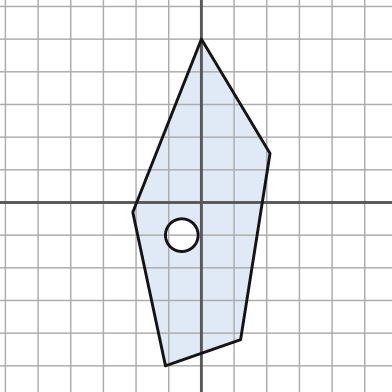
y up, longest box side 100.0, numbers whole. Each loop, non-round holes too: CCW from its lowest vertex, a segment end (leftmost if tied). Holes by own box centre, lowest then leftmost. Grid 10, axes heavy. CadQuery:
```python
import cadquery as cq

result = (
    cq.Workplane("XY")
    .moveTo(-11.0, -50.0)
    .lineTo(12.0, -42.0)
    .lineTo(21.0, 15.0)
    .lineTo(0.0, 50.0)
    .lineTo(-21.0, -3.0)
    .close()
    .moveTo(-6.0, -10.0)
    .circle(5.0)
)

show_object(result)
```